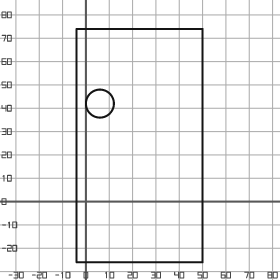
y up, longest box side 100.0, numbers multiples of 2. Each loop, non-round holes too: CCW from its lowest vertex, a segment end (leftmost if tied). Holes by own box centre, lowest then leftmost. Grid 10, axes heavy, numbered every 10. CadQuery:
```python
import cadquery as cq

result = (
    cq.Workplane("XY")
    .moveTo(-4.0, -26.0)
    .lineTo(50.0, -26.0)
    .lineTo(50.0, 74.0)
    .lineTo(-4.0, 74.0)
    .close()
    .moveTo(6.0, 42.0)
    .circle(6.0)
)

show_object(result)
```